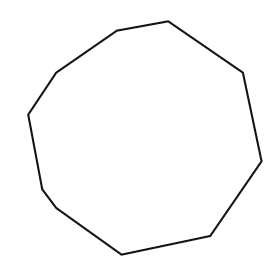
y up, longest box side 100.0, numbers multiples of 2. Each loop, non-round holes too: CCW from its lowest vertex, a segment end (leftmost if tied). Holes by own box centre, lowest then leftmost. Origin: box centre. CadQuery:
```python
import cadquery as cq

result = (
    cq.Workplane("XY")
    .moveTo(-10.0, -50.0)
    .lineTo(28.0, -42.0)
    .lineTo(50.0, -10.0)
    .lineTo(42.0, 28.0)
    .lineTo(10.0, 50.0)
    .lineTo(-12.0, 46.0)
    .lineTo(-38.0, 28.0)
    .lineTo(-50.0, 10.0)
    .lineTo(-44.0, -22.0)
    .lineTo(-38.0, -30.0)
    .close()
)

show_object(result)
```